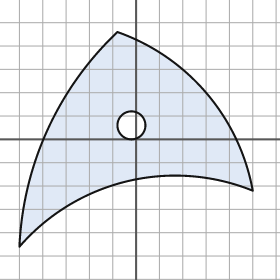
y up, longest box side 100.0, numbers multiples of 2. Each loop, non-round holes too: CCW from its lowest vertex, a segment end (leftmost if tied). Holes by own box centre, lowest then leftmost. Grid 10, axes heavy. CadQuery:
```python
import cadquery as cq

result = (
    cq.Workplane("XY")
    .moveTo(-50.0, -46.0)
    .threePointArc((-4.0, -18.0), (50.0, -22.0))
    .threePointArc((30.0, 20.0), (-8.0, 46.0))
    .threePointArc((-38.0, 4.0), (-50.0, -46.0))
    .close()
    .moveTo(-2.0, 6.0)
    .circle(6.0)
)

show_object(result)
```